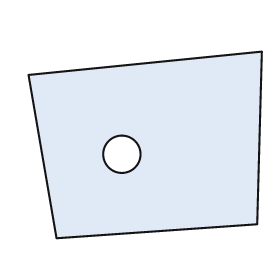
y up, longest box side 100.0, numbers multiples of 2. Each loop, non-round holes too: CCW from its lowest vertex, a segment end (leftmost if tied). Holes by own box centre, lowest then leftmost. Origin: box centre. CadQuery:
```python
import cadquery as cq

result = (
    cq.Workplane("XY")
    .moveTo(-38.0, -40.0)
    .lineTo(48.0, -34.0)
    .lineTo(50.0, 40.0)
    .lineTo(-50.0, 30.0)
    .close()
    .moveTo(-10.0, -4.0)
    .circle(8.0)
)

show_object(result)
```